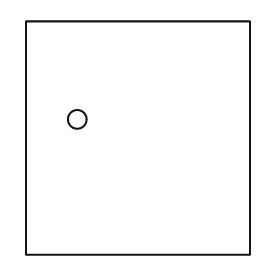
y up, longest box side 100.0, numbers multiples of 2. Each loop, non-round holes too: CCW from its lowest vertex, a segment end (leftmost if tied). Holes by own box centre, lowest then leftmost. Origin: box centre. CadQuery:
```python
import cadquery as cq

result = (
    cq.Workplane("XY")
    .moveTo(-48.0, -50.0)
    .lineTo(48.0, -50.0)
    .lineTo(48.0, 50.0)
    .lineTo(-48.0, 50.0)
    .close()
    .moveTo(-26.0, 8.0)
    .circle(4.0)
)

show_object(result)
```